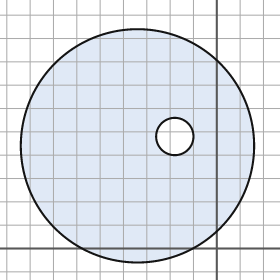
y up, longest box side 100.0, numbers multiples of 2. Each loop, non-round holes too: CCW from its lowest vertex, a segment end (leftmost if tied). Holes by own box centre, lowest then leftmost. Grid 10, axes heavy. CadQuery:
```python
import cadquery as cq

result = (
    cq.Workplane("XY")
    .moveTo(-34.0, 44.0)
    .circle(50.0)
    .moveTo(-18.0, 48.0)
    .circle(8.0)
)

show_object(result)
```